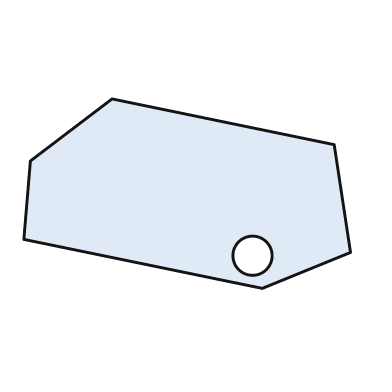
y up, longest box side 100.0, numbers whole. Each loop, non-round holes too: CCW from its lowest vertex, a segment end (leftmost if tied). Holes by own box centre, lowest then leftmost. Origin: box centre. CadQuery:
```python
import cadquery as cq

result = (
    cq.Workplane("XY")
    .moveTo(23.0, -29.0)
    .lineTo(50.0, -18.0)
    .lineTo(45.0, 15.0)
    .lineTo(-23.0, 29.0)
    .lineTo(-48.0, 10.0)
    .lineTo(-50.0, -14.0)
    .close()
    .moveTo(20.0, -19.0)
    .circle(6.0)
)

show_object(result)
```